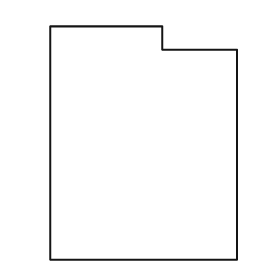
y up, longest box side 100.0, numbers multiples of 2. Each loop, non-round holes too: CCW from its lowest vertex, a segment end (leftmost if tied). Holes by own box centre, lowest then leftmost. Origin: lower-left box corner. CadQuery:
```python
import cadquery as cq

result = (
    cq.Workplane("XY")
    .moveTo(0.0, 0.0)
    .lineTo(80.0, 0.0)
    .lineTo(80.0, 90.0)
    .lineTo(48.0, 90.0)
    .lineTo(48.0, 100.0)
    .lineTo(0.0, 100.0)
    .close()
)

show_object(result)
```